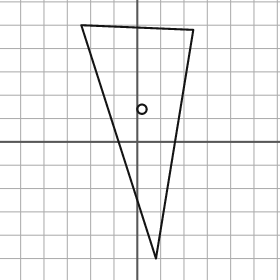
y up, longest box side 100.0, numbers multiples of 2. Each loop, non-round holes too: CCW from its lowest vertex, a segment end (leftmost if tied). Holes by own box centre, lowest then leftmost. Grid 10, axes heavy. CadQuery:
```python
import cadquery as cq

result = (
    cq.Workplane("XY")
    .moveTo(8.0, -50.0)
    .lineTo(24.0, 48.0)
    .lineTo(-24.0, 50.0)
    .close()
    .moveTo(2.0, 14.0)
    .circle(2.0)
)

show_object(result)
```